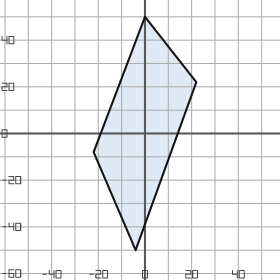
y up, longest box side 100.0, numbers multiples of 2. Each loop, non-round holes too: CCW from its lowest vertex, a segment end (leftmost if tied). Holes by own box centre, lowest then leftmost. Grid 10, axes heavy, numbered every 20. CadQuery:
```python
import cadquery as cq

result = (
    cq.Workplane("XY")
    .moveTo(-4.0, -50.0)
    .lineTo(22.0, 22.0)
    .lineTo(0.0, 50.0)
    .lineTo(-22.0, -8.0)
    .close()
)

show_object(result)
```